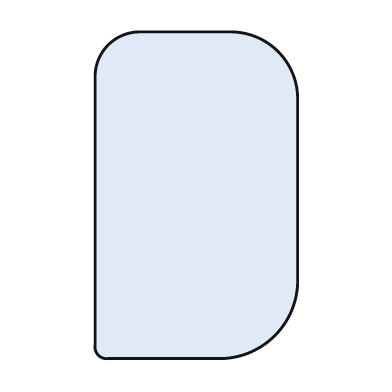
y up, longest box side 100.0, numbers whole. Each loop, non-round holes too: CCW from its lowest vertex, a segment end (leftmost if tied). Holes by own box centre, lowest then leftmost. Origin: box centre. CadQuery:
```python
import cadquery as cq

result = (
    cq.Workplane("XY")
    .moveTo(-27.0, -50.0)
    .lineTo(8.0, -50.0)
    .threePointArc((24.0, -43.0), (31.0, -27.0))
    .lineTo(31.0, 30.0)
    .threePointArc((25.0, 44.0), (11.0, 50.0))
    .lineTo(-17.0, 50.0)
    .threePointArc((-27.0, 46.0), (-31.0, 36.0))
    .lineTo(-31.0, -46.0)
    .threePointArc((-30.0, -49.0), (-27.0, -50.0))
    .close()
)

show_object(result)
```